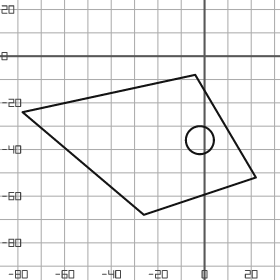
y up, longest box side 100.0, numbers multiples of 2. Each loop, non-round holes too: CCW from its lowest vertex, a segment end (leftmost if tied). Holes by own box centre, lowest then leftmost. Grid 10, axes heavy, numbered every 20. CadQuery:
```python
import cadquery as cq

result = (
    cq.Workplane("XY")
    .moveTo(-26.0, -68.0)
    .lineTo(22.0, -52.0)
    .lineTo(-4.0, -8.0)
    .lineTo(-78.0, -24.0)
    .close()
    .moveTo(-2.0, -36.0)
    .circle(6.0)
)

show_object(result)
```